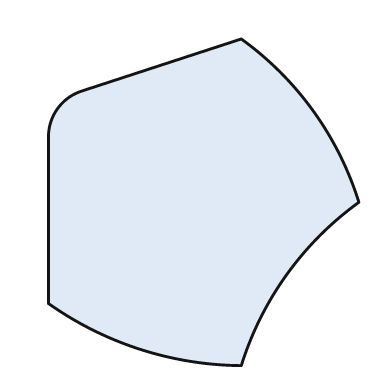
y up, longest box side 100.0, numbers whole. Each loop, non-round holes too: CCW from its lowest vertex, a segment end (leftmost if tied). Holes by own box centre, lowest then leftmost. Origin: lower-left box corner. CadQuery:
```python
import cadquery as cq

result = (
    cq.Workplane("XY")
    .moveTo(59.0, 0.0)
    .threePointArc((73.0, 28.0), (95.0, 50.0))
    .threePointArc((81.0, 78.0), (59.0, 100.0))
    .lineTo(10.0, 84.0)
    .threePointArc((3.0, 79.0), (0.0, 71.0))
    .lineTo(0.0, 19.0)
    .threePointArc((28.0, 5.0), (59.0, 0.0))
    .close()
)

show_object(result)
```